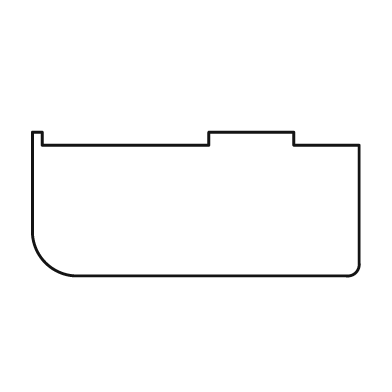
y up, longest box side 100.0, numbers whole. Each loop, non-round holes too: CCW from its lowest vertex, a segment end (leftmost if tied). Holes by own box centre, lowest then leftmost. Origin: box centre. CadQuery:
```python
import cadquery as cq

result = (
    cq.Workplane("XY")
    .moveTo(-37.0, -22.0)
    .lineTo(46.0, -22.0)
    .threePointArc((49.0, -21.0), (50.0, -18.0))
    .lineTo(50.0, 18.0)
    .lineTo(30.0, 18.0)
    .lineTo(30.0, 22.0)
    .lineTo(4.0, 22.0)
    .lineTo(4.0, 18.0)
    .lineTo(-47.0, 18.0)
    .lineTo(-47.0, 22.0)
    .lineTo(-50.0, 22.0)
    .lineTo(-50.0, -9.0)
    .threePointArc((-46.0, -18.0), (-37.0, -22.0))
    .close()
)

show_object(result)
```